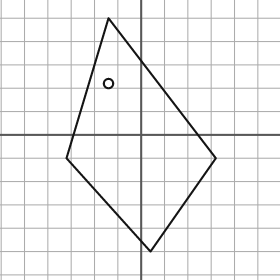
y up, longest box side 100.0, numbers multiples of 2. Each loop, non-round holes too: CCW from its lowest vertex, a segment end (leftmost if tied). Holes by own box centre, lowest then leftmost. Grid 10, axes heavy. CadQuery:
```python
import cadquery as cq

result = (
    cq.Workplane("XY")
    .moveTo(4.0, -50.0)
    .lineTo(32.0, -10.0)
    .lineTo(-14.0, 50.0)
    .lineTo(-32.0, -10.0)
    .close()
    .moveTo(-14.0, 22.0)
    .circle(2.0)
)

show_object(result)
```